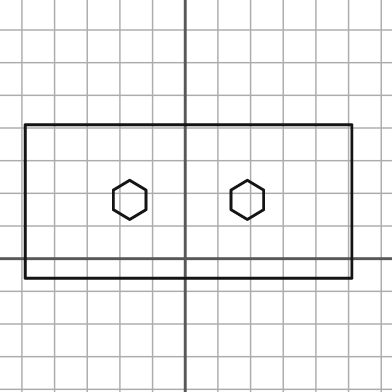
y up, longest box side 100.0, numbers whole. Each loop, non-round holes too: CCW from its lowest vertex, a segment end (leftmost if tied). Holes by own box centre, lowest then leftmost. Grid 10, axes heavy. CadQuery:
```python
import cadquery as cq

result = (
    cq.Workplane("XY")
    .moveTo(-49.0, -6.0)
    .lineTo(51.0, -6.0)
    .lineTo(51.0, 41.0)
    .lineTo(-49.0, 41.0)
    .close()
    .moveTo(-17.0, 12.0)
    .lineTo(-12.0, 15.0)
    .lineTo(-12.0, 21.0)
    .lineTo(-17.0, 24.0)
    .lineTo(-22.0, 21.0)
    .lineTo(-22.0, 15.0)
    .close()
    .moveTo(19.0, 12.0)
    .lineTo(24.0, 15.0)
    .lineTo(24.0, 21.0)
    .lineTo(19.0, 24.0)
    .lineTo(14.0, 21.0)
    .lineTo(14.0, 15.0)
    .close()
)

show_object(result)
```